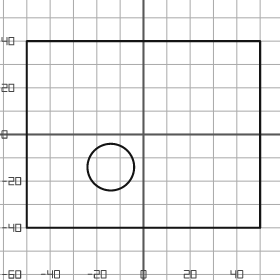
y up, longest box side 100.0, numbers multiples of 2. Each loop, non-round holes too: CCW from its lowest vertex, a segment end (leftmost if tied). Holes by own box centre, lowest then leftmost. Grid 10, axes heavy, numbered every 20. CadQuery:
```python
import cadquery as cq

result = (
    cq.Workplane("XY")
    .moveTo(-50.0, -40.0)
    .lineTo(50.0, -40.0)
    .lineTo(50.0, 40.0)
    .lineTo(-50.0, 40.0)
    .close()
    .moveTo(-14.0, -14.0)
    .circle(10.0)
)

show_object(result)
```